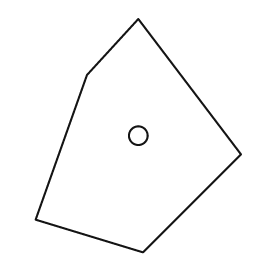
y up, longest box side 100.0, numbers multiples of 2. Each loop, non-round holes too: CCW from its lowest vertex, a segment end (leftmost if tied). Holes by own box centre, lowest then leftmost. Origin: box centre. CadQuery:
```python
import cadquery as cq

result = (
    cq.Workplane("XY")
    .moveTo(2.0, -50.0)
    .lineTo(44.0, -8.0)
    .lineTo(0.0, 50.0)
    .lineTo(-22.0, 26.0)
    .lineTo(-44.0, -36.0)
    .close()
    .moveTo(0.0, 0.0)
    .circle(4.0)
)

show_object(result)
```